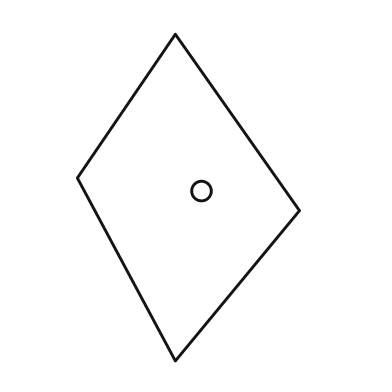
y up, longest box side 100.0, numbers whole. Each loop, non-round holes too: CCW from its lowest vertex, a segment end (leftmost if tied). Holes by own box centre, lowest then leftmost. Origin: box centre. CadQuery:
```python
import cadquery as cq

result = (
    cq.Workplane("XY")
    .moveTo(-4.0, -50.0)
    .lineTo(34.0, -4.0)
    .lineTo(-4.0, 50.0)
    .lineTo(-34.0, 6.0)
    .close()
    .moveTo(4.0, 2.0)
    .circle(3.0)
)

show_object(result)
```